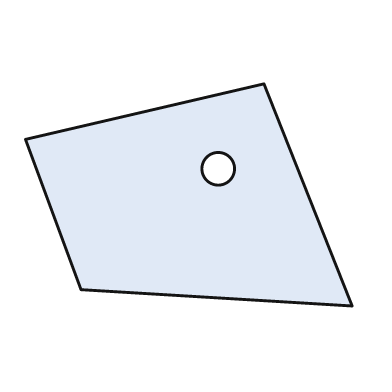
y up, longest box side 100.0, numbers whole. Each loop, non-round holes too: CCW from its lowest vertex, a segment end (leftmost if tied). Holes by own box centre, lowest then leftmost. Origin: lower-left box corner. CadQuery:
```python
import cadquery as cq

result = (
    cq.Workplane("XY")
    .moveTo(100.0, 0.0)
    .lineTo(73.0, 68.0)
    .lineTo(0.0, 51.0)
    .lineTo(17.0, 5.0)
    .close()
    .moveTo(59.0, 42.0)
    .circle(5.0)
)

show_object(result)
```